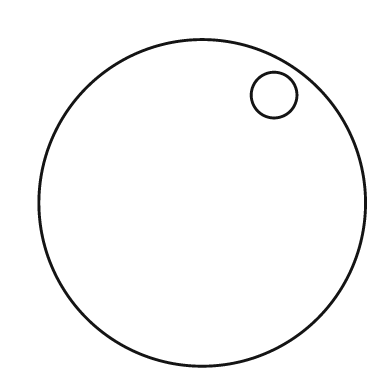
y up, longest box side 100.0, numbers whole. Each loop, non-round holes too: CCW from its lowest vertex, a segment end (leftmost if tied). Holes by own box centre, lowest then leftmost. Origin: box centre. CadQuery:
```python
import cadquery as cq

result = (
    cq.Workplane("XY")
    .moveTo(0.0, 0.0)
    .circle(50.0)
    .moveTo(22.0, 33.0)
    .circle(7.0)
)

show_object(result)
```